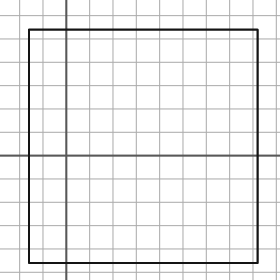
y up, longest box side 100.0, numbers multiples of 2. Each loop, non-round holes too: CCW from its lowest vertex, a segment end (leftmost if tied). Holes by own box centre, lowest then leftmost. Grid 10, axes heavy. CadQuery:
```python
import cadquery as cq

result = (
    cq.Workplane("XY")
    .moveTo(-16.0, -46.0)
    .lineTo(82.0, -46.0)
    .lineTo(82.0, 54.0)
    .lineTo(-16.0, 54.0)
    .close()
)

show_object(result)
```